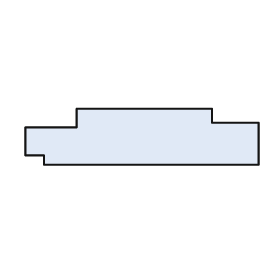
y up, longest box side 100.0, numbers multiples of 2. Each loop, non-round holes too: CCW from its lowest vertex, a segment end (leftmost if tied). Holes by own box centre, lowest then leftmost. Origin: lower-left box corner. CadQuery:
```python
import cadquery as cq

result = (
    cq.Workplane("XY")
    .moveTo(8.0, 0.0)
    .lineTo(100.0, 0.0)
    .lineTo(100.0, 18.0)
    .lineTo(80.0, 18.0)
    .lineTo(80.0, 24.0)
    .lineTo(22.0, 24.0)
    .lineTo(22.0, 16.0)
    .lineTo(0.0, 16.0)
    .lineTo(0.0, 4.0)
    .lineTo(8.0, 4.0)
    .close()
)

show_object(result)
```